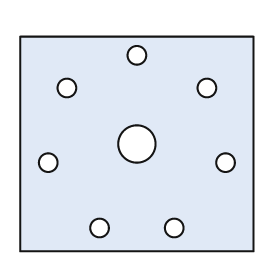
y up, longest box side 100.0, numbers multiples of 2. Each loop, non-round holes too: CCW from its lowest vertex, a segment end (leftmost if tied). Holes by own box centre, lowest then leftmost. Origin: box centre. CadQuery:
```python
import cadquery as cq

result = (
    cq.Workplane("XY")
    .moveTo(-50.0, -46.0)
    .lineTo(50.0, -46.0)
    .lineTo(50.0, 46.0)
    .lineTo(-50.0, 46.0)
    .close()
    .moveTo(-16.0, -36.0)
    .circle(4.0)
    .moveTo(16.0, -36.0)
    .circle(4.0)
    .moveTo(-38.0, -8.0)
    .circle(4.0)
    .moveTo(38.0, -8.0)
    .circle(4.0)
    .moveTo(0.0, 0.0)
    .circle(8.0)
    .moveTo(-30.0, 24.0)
    .circle(4.0)
    .moveTo(30.0, 24.0)
    .circle(4.0)
    .moveTo(0.0, 38.0)
    .circle(4.0)
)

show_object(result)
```